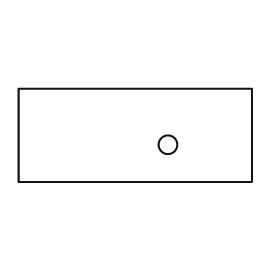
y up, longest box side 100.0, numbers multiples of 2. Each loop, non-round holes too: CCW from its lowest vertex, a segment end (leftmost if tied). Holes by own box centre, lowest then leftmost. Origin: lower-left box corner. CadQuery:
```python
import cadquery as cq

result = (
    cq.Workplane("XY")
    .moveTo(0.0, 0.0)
    .lineTo(100.0, 0.0)
    .lineTo(100.0, 40.0)
    .lineTo(0.0, 40.0)
    .close()
    .moveTo(64.0, 16.0)
    .circle(4.0)
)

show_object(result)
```